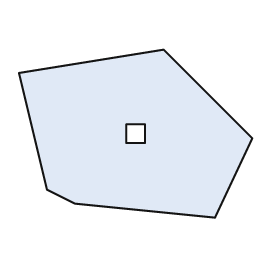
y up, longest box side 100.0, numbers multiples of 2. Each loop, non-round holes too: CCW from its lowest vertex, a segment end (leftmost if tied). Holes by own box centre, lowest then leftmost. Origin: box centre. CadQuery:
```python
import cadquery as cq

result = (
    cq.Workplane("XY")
    .moveTo(34.0, -36.0)
    .lineTo(50.0, -2.0)
    .lineTo(12.0, 36.0)
    .lineTo(-50.0, 26.0)
    .lineTo(-38.0, -24.0)
    .lineTo(-26.0, -30.0)
    .close()
    .moveTo(-4.0, -4.0)
    .lineTo(4.0, -4.0)
    .lineTo(4.0, 4.0)
    .lineTo(-4.0, 4.0)
    .close()
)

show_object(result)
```